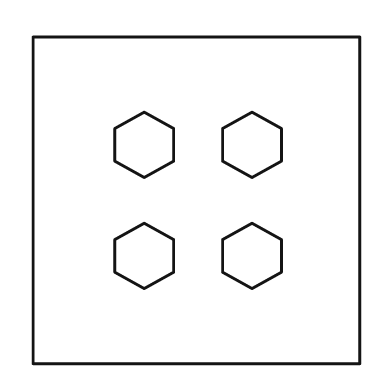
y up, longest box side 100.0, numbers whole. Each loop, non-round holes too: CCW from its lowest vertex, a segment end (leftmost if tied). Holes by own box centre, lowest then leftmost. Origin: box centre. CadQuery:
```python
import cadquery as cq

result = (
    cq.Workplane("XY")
    .moveTo(-50.0, -50.0)
    .lineTo(50.0, -50.0)
    .lineTo(50.0, 50.0)
    .lineTo(-50.0, 50.0)
    .close()
    .moveTo(-16.0, -27.0)
    .lineTo(-7.0, -22.0)
    .lineTo(-7.0, -12.0)
    .lineTo(-16.0, -7.0)
    .lineTo(-25.0, -12.0)
    .lineTo(-25.0, -22.0)
    .close()
    .moveTo(17.0, -27.0)
    .lineTo(26.0, -22.0)
    .lineTo(26.0, -12.0)
    .lineTo(17.0, -7.0)
    .lineTo(8.0, -12.0)
    .lineTo(8.0, -22.0)
    .close()
    .moveTo(-16.0, 7.0)
    .lineTo(-7.0, 12.0)
    .lineTo(-7.0, 22.0)
    .lineTo(-16.0, 27.0)
    .lineTo(-25.0, 22.0)
    .lineTo(-25.0, 12.0)
    .close()
    .moveTo(17.0, 7.0)
    .lineTo(26.0, 12.0)
    .lineTo(26.0, 22.0)
    .lineTo(17.0, 27.0)
    .lineTo(8.0, 22.0)
    .lineTo(8.0, 12.0)
    .close()
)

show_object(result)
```